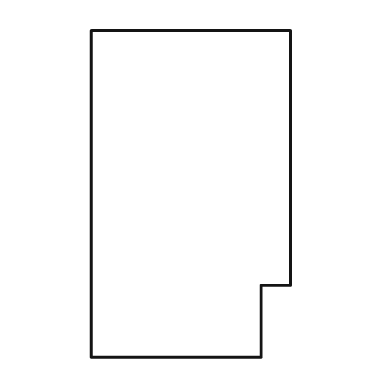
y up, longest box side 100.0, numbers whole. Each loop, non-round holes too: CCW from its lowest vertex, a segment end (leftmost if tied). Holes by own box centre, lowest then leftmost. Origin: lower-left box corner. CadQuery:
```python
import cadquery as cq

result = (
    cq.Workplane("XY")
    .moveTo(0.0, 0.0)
    .lineTo(52.0, 0.0)
    .lineTo(52.0, 22.0)
    .lineTo(61.0, 22.0)
    .lineTo(61.0, 100.0)
    .lineTo(0.0, 100.0)
    .close()
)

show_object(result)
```